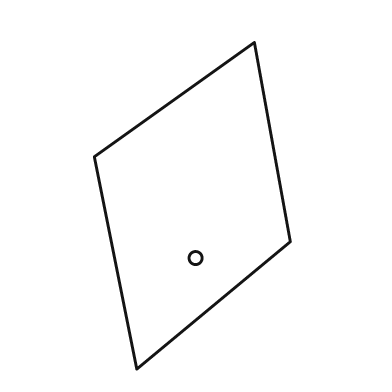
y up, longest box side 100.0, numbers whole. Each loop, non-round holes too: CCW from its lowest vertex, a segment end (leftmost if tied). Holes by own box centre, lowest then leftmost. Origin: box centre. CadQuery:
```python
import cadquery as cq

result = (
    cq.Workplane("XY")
    .moveTo(-17.0, -50.0)
    .lineTo(30.0, -11.0)
    .lineTo(19.0, 50.0)
    .lineTo(-30.0, 15.0)
    .close()
    .moveTo(1.0, -16.0)
    .circle(2.0)
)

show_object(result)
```